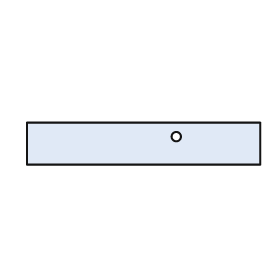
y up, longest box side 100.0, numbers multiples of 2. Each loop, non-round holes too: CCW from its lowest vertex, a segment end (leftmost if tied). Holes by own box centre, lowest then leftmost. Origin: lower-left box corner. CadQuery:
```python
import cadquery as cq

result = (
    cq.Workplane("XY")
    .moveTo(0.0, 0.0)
    .lineTo(100.0, 0.0)
    .lineTo(100.0, 18.0)
    .lineTo(0.0, 18.0)
    .close()
    .moveTo(64.0, 12.0)
    .circle(2.0)
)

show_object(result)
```